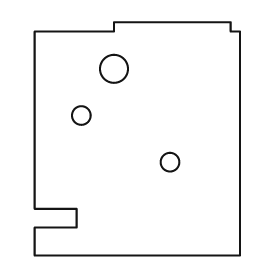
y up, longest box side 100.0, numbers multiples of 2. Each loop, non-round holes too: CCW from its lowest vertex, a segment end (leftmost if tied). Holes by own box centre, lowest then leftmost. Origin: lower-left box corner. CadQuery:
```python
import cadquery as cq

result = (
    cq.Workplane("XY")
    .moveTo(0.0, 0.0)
    .lineTo(88.0, 0.0)
    .lineTo(88.0, 96.0)
    .lineTo(84.0, 96.0)
    .lineTo(84.0, 100.0)
    .lineTo(34.0, 100.0)
    .lineTo(34.0, 96.0)
    .lineTo(0.0, 96.0)
    .lineTo(0.0, 20.0)
    .lineTo(18.0, 20.0)
    .lineTo(18.0, 12.0)
    .lineTo(0.0, 12.0)
    .close()
    .moveTo(58.0, 40.0)
    .circle(4.0)
    .moveTo(20.0, 60.0)
    .circle(4.0)
    .moveTo(34.0, 80.0)
    .circle(6.0)
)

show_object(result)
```